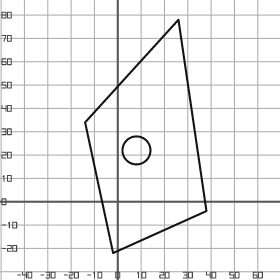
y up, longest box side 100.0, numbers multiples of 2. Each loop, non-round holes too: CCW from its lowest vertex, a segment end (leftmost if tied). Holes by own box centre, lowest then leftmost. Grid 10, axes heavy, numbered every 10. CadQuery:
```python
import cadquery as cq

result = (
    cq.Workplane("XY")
    .moveTo(-2.0, -22.0)
    .lineTo(38.0, -4.0)
    .lineTo(26.0, 78.0)
    .lineTo(-14.0, 34.0)
    .close()
    .moveTo(8.0, 22.0)
    .circle(6.0)
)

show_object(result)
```